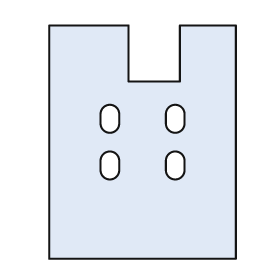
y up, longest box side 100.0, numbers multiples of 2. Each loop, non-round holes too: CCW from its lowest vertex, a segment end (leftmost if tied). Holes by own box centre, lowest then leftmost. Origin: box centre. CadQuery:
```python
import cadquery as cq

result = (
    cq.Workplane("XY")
    .moveTo(-40.0, -50.0)
    .lineTo(40.0, -50.0)
    .lineTo(40.0, 50.0)
    .lineTo(16.0, 50.0)
    .lineTo(16.0, 26.0)
    .lineTo(-6.0, 26.0)
    .lineTo(-6.0, 50.0)
    .lineTo(-40.0, 50.0)
    .close()
    .moveTo(-18.0, -12.0)
    .threePointArc((-14.0, -16.0), (-10.0, -12.0))
    .lineTo(-10.0, -8.0)
    .threePointArc((-14.0, -4.0), (-18.0, -8.0))
    .close()
    .moveTo(10.0, -12.0)
    .threePointArc((14.0, -16.0), (18.0, -12.0))
    .lineTo(18.0, -8.0)
    .threePointArc((14.0, -4.0), (10.0, -8.0))
    .close()
    .moveTo(-18.0, 8.0)
    .threePointArc((-14.0, 4.0), (-10.0, 8.0))
    .lineTo(-10.0, 12.0)
    .threePointArc((-14.0, 16.0), (-18.0, 12.0))
    .close()
    .moveTo(10.0, 8.0)
    .threePointArc((14.0, 4.0), (18.0, 8.0))
    .lineTo(18.0, 12.0)
    .threePointArc((14.0, 16.0), (10.0, 12.0))
    .close()
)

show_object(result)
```